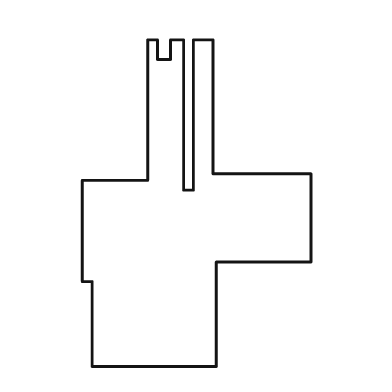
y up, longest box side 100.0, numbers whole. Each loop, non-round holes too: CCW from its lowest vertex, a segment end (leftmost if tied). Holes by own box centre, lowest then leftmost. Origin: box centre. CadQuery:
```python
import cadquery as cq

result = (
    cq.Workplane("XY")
    .moveTo(-32.0, -50.0)
    .lineTo(6.0, -50.0)
    .lineTo(6.0, -18.0)
    .lineTo(35.0, -18.0)
    .lineTo(35.0, 9.0)
    .lineTo(5.0, 9.0)
    .lineTo(5.0, 50.0)
    .lineTo(-1.0, 50.0)
    .lineTo(-1.0, 4.0)
    .lineTo(-4.0, 4.0)
    .lineTo(-4.0, 50.0)
    .lineTo(-8.0, 50.0)
    .lineTo(-8.0, 44.0)
    .lineTo(-12.0, 44.0)
    .lineTo(-12.0, 50.0)
    .lineTo(-15.0, 50.0)
    .lineTo(-15.0, 7.0)
    .lineTo(-35.0, 7.0)
    .lineTo(-35.0, -24.0)
    .lineTo(-32.0, -24.0)
    .close()
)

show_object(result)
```